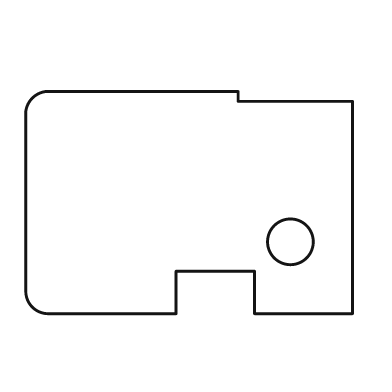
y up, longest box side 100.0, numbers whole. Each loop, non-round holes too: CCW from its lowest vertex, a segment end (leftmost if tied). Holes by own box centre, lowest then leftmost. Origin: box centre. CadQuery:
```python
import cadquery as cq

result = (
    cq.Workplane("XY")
    .moveTo(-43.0, -34.0)
    .lineTo(-4.0, -34.0)
    .lineTo(-4.0, -21.0)
    .lineTo(20.0, -21.0)
    .lineTo(20.0, -34.0)
    .lineTo(50.0, -34.0)
    .lineTo(50.0, 31.0)
    .lineTo(15.0, 31.0)
    .lineTo(15.0, 34.0)
    .lineTo(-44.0, 34.0)
    .threePointArc((-48.0, 32.0), (-50.0, 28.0))
    .lineTo(-50.0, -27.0)
    .threePointArc((-48.0, -32.0), (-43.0, -34.0))
    .close()
    .moveTo(31.0, -12.0)
    .circle(7.0)
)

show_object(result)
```